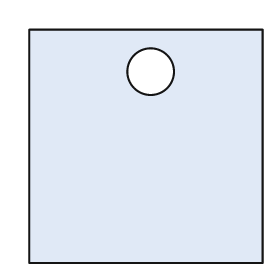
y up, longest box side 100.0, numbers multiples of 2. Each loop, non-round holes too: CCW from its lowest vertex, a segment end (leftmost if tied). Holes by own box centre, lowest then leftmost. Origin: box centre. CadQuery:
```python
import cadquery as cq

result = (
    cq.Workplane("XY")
    .moveTo(-50.0, -50.0)
    .lineTo(50.0, -50.0)
    .lineTo(50.0, 50.0)
    .lineTo(-50.0, 50.0)
    .close()
    .moveTo(2.0, 32.0)
    .circle(10.0)
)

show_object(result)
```